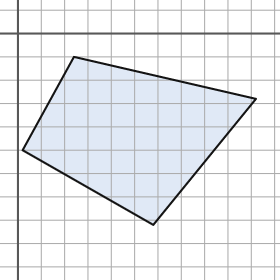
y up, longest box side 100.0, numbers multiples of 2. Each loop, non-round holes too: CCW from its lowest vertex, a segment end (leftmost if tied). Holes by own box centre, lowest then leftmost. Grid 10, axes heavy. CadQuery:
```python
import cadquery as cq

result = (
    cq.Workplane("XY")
    .moveTo(58.0, -82.0)
    .lineTo(102.0, -28.0)
    .lineTo(24.0, -10.0)
    .lineTo(2.0, -50.0)
    .close()
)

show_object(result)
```